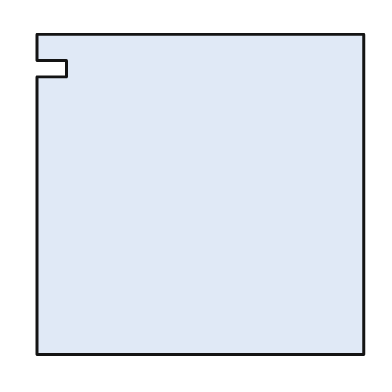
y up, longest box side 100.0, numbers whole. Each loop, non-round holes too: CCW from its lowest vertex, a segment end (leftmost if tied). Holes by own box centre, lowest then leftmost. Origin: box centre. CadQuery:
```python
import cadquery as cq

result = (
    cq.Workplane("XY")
    .moveTo(-50.0, -49.0)
    .lineTo(50.0, -49.0)
    .lineTo(50.0, 49.0)
    .lineTo(-50.0, 49.0)
    .lineTo(-50.0, 41.0)
    .lineTo(-41.0, 41.0)
    .lineTo(-41.0, 36.0)
    .lineTo(-50.0, 36.0)
    .close()
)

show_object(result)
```